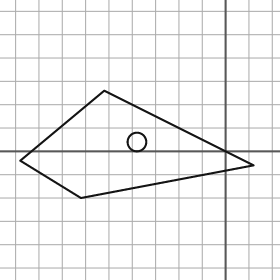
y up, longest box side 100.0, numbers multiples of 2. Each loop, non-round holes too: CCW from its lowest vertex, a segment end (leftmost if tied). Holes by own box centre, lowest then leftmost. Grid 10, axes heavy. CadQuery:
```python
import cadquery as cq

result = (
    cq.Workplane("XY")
    .moveTo(-62.0, -20.0)
    .lineTo(12.0, -6.0)
    .lineTo(-52.0, 26.0)
    .lineTo(-88.0, -4.0)
    .close()
    .moveTo(-38.0, 4.0)
    .circle(4.0)
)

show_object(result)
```